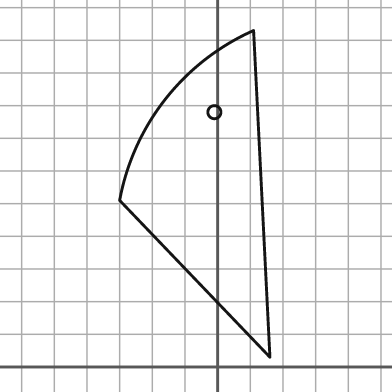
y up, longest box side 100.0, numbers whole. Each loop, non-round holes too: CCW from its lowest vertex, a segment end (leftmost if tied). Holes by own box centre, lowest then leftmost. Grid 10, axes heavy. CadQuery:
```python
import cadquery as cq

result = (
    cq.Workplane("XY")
    .moveTo(16.0, 3.0)
    .lineTo(11.0, 103.0)
    .threePointArc((-16.0, 82.0), (-30.0, 51.0))
    .close()
    .moveTo(-1.0, 78.0)
    .circle(2.0)
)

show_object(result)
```